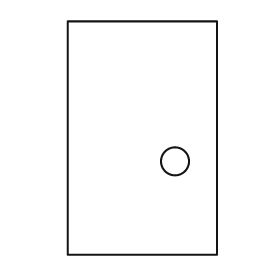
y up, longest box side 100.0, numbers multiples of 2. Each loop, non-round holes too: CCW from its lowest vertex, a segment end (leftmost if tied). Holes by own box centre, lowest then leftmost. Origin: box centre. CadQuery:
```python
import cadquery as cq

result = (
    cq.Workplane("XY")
    .moveTo(-32.0, -50.0)
    .lineTo(32.0, -50.0)
    .lineTo(32.0, 50.0)
    .lineTo(-32.0, 50.0)
    .close()
    .moveTo(14.0, -10.0)
    .circle(6.0)
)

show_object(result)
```